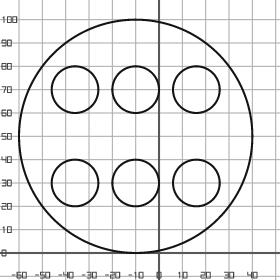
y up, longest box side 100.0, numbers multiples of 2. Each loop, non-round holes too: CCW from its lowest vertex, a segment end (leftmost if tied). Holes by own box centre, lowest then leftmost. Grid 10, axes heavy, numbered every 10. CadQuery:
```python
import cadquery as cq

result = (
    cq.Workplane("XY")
    .moveTo(-10.0, 50.0)
    .circle(50.0)
    .moveTo(-36.0, 30.0)
    .circle(10.0)
    .moveTo(-10.0, 30.0)
    .circle(10.0)
    .moveTo(16.0, 30.0)
    .circle(10.0)
    .moveTo(-36.0, 70.0)
    .circle(10.0)
    .moveTo(-10.0, 70.0)
    .circle(10.0)
    .moveTo(16.0, 70.0)
    .circle(10.0)
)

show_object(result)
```